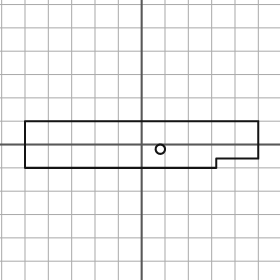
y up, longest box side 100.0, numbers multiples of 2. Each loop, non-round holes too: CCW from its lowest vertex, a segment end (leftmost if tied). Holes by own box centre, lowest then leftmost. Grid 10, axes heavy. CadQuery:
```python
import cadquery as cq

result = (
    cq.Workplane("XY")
    .moveTo(-50.0, -10.0)
    .lineTo(32.0, -10.0)
    .lineTo(32.0, -6.0)
    .lineTo(50.0, -6.0)
    .lineTo(50.0, 10.0)
    .lineTo(-50.0, 10.0)
    .close()
    .moveTo(8.0, -2.0)
    .circle(2.0)
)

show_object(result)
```